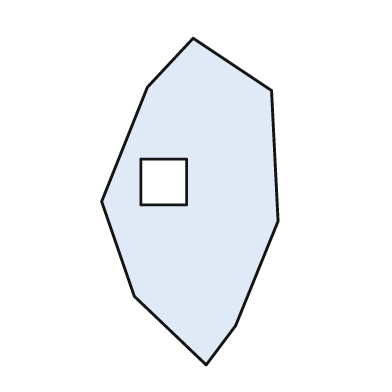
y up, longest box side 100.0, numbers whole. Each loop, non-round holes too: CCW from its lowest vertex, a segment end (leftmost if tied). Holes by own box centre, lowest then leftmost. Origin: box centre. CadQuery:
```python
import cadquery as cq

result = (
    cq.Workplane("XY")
    .moveTo(5.0, -50.0)
    .lineTo(14.0, -38.0)
    .lineTo(27.0, -6.0)
    .lineTo(25.0, 34.0)
    .lineTo(1.0, 50.0)
    .lineTo(-13.0, 35.0)
    .lineTo(-27.0, 0.0)
    .lineTo(-17.0, -29.0)
    .close()
    .moveTo(-15.0, -1.0)
    .lineTo(-1.0, -1.0)
    .lineTo(-1.0, 13.0)
    .lineTo(-15.0, 13.0)
    .close()
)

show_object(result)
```